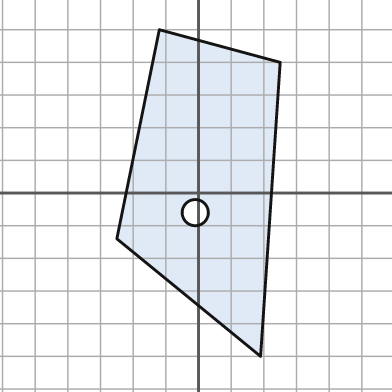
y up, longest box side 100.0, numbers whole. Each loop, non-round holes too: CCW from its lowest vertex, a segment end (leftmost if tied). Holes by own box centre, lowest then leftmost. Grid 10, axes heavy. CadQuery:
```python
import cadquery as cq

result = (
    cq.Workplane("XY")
    .moveTo(19.0, -50.0)
    .lineTo(25.0, 40.0)
    .lineTo(-12.0, 50.0)
    .lineTo(-25.0, -14.0)
    .close()
    .moveTo(-1.0, -6.0)
    .circle(4.0)
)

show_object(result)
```